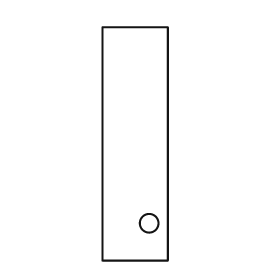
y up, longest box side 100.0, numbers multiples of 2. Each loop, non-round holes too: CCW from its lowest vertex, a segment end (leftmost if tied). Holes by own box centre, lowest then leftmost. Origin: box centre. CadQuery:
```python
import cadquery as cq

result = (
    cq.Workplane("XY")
    .moveTo(-14.0, -50.0)
    .lineTo(14.0, -50.0)
    .lineTo(14.0, 50.0)
    .lineTo(-14.0, 50.0)
    .close()
    .moveTo(6.0, -34.0)
    .circle(4.0)
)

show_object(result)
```